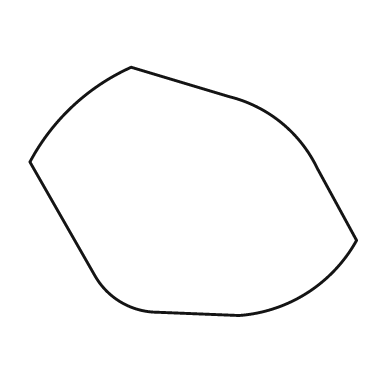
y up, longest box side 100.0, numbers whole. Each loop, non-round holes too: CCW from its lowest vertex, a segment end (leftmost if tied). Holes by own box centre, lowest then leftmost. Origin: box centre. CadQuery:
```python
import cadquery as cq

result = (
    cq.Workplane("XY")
    .moveTo(14.0, -38.0)
    .threePointArc((35.0, -31.0), (50.0, -15.0))
    .lineTo(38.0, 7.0)
    .threePointArc((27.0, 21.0), (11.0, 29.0))
    .lineTo(-19.0, 38.0)
    .threePointArc((-37.0, 26.0), (-50.0, 9.0))
    .lineTo(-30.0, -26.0)
    .threePointArc((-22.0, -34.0), (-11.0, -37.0))
    .close()
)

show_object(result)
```